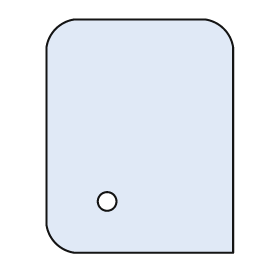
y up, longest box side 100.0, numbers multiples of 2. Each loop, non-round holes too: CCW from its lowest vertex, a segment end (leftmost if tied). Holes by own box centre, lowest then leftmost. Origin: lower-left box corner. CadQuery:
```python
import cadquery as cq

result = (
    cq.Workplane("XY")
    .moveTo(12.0, 0.0)
    .lineTo(80.0, 0.0)
    .lineTo(80.0, 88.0)
    .threePointArc((76.0, 96.0), (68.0, 100.0))
    .lineTo(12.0, 100.0)
    .threePointArc((4.0, 96.0), (0.0, 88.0))
    .lineTo(0.0, 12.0)
    .threePointArc((4.0, 4.0), (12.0, 0.0))
    .close()
    .moveTo(26.0, 22.0)
    .circle(4.0)
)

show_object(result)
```